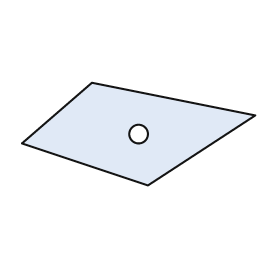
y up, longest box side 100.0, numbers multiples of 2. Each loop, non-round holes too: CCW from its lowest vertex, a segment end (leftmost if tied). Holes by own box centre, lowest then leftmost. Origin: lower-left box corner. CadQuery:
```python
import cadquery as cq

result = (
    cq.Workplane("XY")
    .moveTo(54.0, 0.0)
    .lineTo(100.0, 30.0)
    .lineTo(30.0, 44.0)
    .lineTo(0.0, 18.0)
    .close()
    .moveTo(50.0, 22.0)
    .circle(4.0)
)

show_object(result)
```